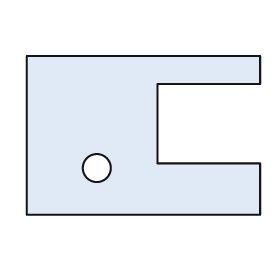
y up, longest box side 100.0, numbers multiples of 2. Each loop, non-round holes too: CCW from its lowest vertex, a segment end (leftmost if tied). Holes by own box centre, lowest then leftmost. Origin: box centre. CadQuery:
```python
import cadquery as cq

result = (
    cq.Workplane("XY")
    .moveTo(-50.0, -34.0)
    .lineTo(50.0, -34.0)
    .lineTo(50.0, -12.0)
    .lineTo(6.0, -12.0)
    .lineTo(6.0, 22.0)
    .lineTo(50.0, 22.0)
    .lineTo(50.0, 34.0)
    .lineTo(-50.0, 34.0)
    .close()
    .moveTo(-20.0, -14.0)
    .circle(6.0)
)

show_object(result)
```